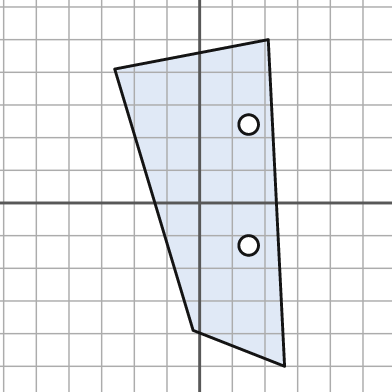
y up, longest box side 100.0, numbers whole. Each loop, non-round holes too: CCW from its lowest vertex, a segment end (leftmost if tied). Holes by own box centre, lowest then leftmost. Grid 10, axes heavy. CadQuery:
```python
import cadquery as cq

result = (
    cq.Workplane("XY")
    .moveTo(26.0, -50.0)
    .lineTo(21.0, 50.0)
    .lineTo(-26.0, 41.0)
    .lineTo(-2.0, -39.0)
    .close()
    .moveTo(15.0, -13.0)
    .circle(3.0)
    .moveTo(15.0, 24.0)
    .circle(3.0)
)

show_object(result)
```